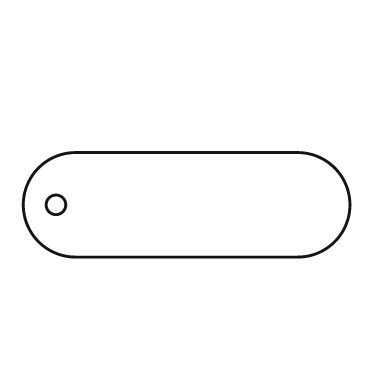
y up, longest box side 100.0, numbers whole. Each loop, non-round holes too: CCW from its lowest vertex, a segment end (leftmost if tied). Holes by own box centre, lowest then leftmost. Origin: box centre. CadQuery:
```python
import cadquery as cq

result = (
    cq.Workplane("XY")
    .moveTo(-34.0, -16.0)
    .lineTo(34.0, -16.0)
    .threePointArc((50.0, 0.0), (34.0, 16.0))
    .lineTo(-34.0, 16.0)
    .threePointArc((-50.0, 0.0), (-34.0, -16.0))
    .close()
    .moveTo(-40.0, 0.0)
    .circle(3.0)
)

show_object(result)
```